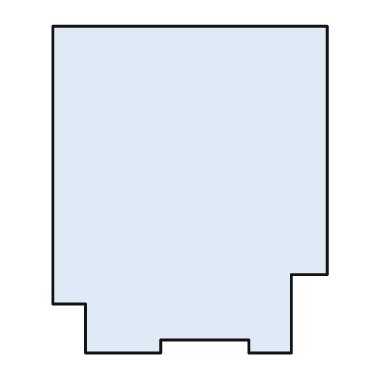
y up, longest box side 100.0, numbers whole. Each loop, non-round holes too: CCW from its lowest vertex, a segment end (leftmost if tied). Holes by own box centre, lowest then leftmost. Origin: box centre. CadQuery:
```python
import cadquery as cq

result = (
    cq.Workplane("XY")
    .moveTo(-32.0, -50.0)
    .lineTo(-9.0, -50.0)
    .lineTo(-9.0, -46.0)
    .lineTo(18.0, -46.0)
    .lineTo(18.0, -50.0)
    .lineTo(31.0, -50.0)
    .lineTo(31.0, -26.0)
    .lineTo(42.0, -26.0)
    .lineTo(42.0, 50.0)
    .lineTo(-42.0, 50.0)
    .lineTo(-42.0, -35.0)
    .lineTo(-32.0, -35.0)
    .close()
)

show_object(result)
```